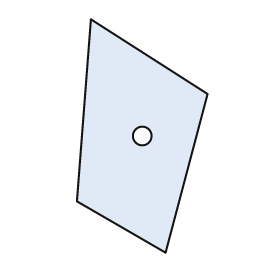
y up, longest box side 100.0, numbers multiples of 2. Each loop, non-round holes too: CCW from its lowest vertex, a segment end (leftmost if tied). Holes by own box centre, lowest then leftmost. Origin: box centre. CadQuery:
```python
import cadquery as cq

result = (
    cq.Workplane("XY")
    .moveTo(10.0, -50.0)
    .lineTo(28.0, 18.0)
    .lineTo(-22.0, 50.0)
    .lineTo(-28.0, -28.0)
    .close()
    .moveTo(0.0, 0.0)
    .circle(4.0)
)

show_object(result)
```